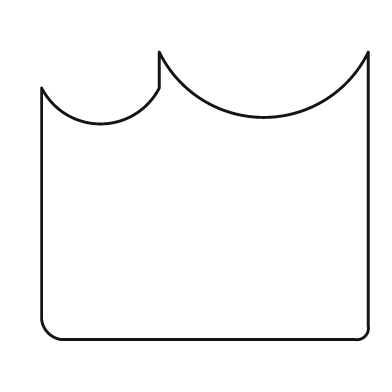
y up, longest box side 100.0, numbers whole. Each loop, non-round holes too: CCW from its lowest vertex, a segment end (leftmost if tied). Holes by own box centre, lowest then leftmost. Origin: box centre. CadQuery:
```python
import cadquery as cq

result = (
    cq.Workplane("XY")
    .moveTo(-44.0, -44.0)
    .lineTo(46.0, -44.0)
    .threePointArc((49.0, -43.0), (50.0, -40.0))
    .lineTo(50.0, 44.0)
    .threePointArc((18.0, 24.0), (-14.0, 44.0))
    .lineTo(-14.0, 33.0)
    .threePointArc((-32.0, 22.0), (-50.0, 33.0))
    .lineTo(-50.0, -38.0)
    .threePointArc((-48.0, -42.0), (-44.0, -44.0))
    .close()
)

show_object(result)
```